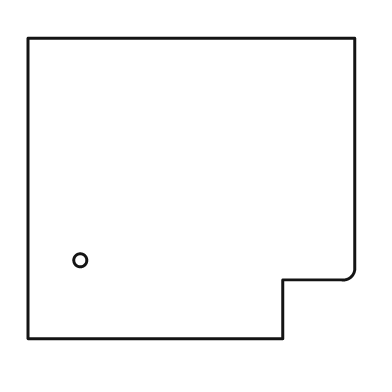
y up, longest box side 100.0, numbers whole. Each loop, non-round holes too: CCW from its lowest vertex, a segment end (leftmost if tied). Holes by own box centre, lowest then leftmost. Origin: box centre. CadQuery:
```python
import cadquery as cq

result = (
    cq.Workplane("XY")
    .moveTo(-50.0, -46.0)
    .lineTo(28.0, -46.0)
    .lineTo(28.0, -28.0)
    .lineTo(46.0, -28.0)
    .threePointArc((49.0, -27.0), (50.0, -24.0))
    .lineTo(50.0, 46.0)
    .lineTo(-50.0, 46.0)
    .close()
    .moveTo(-34.0, -22.0)
    .circle(2.0)
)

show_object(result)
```